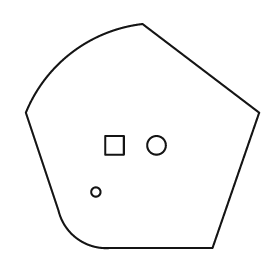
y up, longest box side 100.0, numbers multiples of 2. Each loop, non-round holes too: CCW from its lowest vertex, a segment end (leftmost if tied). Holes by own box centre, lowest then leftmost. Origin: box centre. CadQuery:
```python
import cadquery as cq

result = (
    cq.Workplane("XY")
    .moveTo(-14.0, -48.0)
    .lineTo(30.0, -48.0)
    .lineTo(50.0, 10.0)
    .lineTo(0.0, 48.0)
    .threePointArc((-30.0, 36.0), (-50.0, 10.0))
    .lineTo(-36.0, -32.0)
    .threePointArc((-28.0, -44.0), (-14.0, -48.0))
    .close()
    .moveTo(-20.0, -24.0)
    .circle(2.0)
    .moveTo(-16.0, -8.0)
    .lineTo(-8.0, -8.0)
    .lineTo(-8.0, 0.0)
    .lineTo(-16.0, 0.0)
    .close()
    .moveTo(6.0, -4.0)
    .circle(4.0)
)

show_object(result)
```